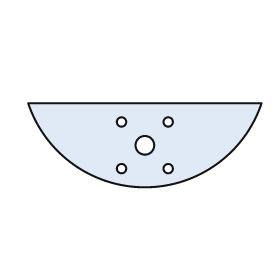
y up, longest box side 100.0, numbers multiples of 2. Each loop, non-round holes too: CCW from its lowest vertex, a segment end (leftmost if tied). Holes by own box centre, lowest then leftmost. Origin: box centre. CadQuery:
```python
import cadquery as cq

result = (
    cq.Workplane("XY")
    .moveTo(-50.0, 18.0)
    .threePointArc((0.0, -18.0), (50.0, 18.0))
    .close()
    .moveTo(-10.0, -10.0)
    .circle(2.0)
    .moveTo(10.0, -10.0)
    .circle(2.0)
    .moveTo(0.0, 0.0)
    .circle(4.0)
    .moveTo(-10.0, 10.0)
    .circle(2.0)
    .moveTo(10.0, 10.0)
    .circle(2.0)
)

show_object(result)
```